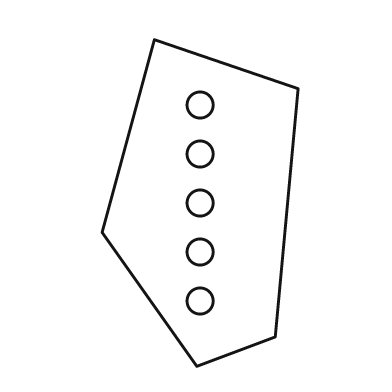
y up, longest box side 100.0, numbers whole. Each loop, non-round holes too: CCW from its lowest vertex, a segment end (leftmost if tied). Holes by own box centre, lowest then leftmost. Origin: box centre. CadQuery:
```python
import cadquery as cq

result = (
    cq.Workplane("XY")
    .moveTo(-1.0, -50.0)
    .lineTo(23.0, -41.0)
    .lineTo(30.0, 35.0)
    .lineTo(-14.0, 50.0)
    .lineTo(-30.0, -9.0)
    .close()
    .moveTo(0.0, -30.0)
    .circle(4.0)
    .moveTo(0.0, -15.0)
    .circle(4.0)
    .moveTo(0.0, 0.0)
    .circle(4.0)
    .moveTo(0.0, 15.0)
    .circle(4.0)
    .moveTo(0.0, 30.0)
    .circle(4.0)
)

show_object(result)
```